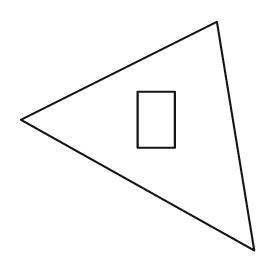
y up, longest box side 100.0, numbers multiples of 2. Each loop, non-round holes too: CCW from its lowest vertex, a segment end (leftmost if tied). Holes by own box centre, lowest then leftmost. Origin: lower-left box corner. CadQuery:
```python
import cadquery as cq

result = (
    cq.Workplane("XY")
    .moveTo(100.0, 0.0)
    .lineTo(84.0, 98.0)
    .lineTo(0.0, 56.0)
    .close()
    .moveTo(50.0, 44.0)
    .lineTo(66.0, 44.0)
    .lineTo(66.0, 68.0)
    .lineTo(50.0, 68.0)
    .close()
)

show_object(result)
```